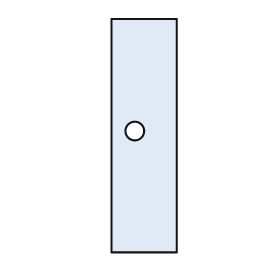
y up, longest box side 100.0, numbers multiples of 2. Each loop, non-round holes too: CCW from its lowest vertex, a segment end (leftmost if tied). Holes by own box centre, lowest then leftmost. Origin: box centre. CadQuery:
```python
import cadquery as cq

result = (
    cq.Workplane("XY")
    .moveTo(-14.0, -50.0)
    .lineTo(14.0, -50.0)
    .lineTo(14.0, 50.0)
    .lineTo(-14.0, 50.0)
    .close()
    .moveTo(-4.0, 2.0)
    .circle(4.0)
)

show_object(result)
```